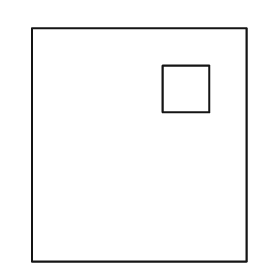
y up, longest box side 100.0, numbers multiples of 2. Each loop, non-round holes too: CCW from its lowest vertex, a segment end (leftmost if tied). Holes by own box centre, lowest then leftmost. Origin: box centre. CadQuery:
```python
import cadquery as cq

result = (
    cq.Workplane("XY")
    .moveTo(-46.0, -50.0)
    .lineTo(46.0, -50.0)
    .lineTo(46.0, 50.0)
    .lineTo(-46.0, 50.0)
    .close()
    .moveTo(10.0, 14.0)
    .lineTo(30.0, 14.0)
    .lineTo(30.0, 34.0)
    .lineTo(10.0, 34.0)
    .close()
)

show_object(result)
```